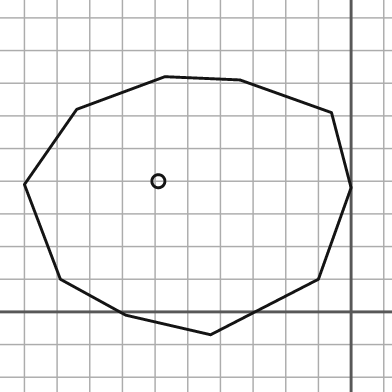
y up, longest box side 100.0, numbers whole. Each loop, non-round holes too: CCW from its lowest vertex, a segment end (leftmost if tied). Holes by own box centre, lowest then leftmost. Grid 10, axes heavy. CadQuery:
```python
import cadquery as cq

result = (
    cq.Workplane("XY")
    .moveTo(-43.0, -7.0)
    .lineTo(-10.0, 10.0)
    .lineTo(0.0, 38.0)
    .lineTo(-6.0, 61.0)
    .lineTo(-34.0, 71.0)
    .lineTo(-57.0, 72.0)
    .lineTo(-84.0, 62.0)
    .lineTo(-100.0, 39.0)
    .lineTo(-89.0, 10.0)
    .lineTo(-69.0, -1.0)
    .close()
    .moveTo(-59.0, 40.0)
    .circle(2.0)
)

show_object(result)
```